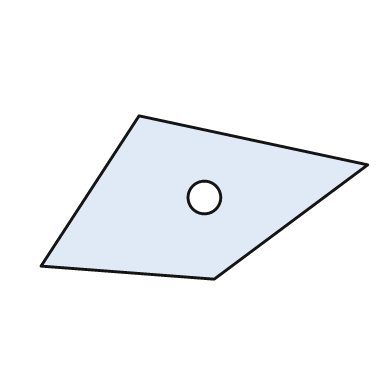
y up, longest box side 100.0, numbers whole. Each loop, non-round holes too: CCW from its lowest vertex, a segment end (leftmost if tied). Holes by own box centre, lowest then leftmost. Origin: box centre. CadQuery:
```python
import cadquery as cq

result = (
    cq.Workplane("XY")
    .moveTo(3.0, -25.0)
    .lineTo(50.0, 10.0)
    .lineTo(-20.0, 25.0)
    .lineTo(-50.0, -21.0)
    .close()
    .moveTo(0.0, 0.0)
    .circle(5.0)
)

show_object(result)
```